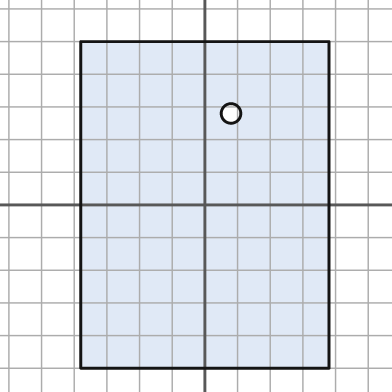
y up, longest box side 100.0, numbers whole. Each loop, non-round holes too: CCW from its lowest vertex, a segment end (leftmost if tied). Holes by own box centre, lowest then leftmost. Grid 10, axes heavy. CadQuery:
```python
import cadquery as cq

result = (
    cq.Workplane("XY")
    .moveTo(-38.0, -50.0)
    .lineTo(38.0, -50.0)
    .lineTo(38.0, 50.0)
    .lineTo(-38.0, 50.0)
    .close()
    .moveTo(8.0, 28.0)
    .circle(3.0)
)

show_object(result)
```